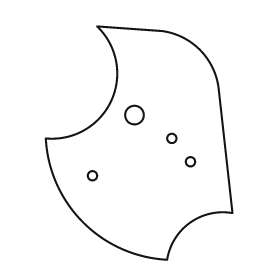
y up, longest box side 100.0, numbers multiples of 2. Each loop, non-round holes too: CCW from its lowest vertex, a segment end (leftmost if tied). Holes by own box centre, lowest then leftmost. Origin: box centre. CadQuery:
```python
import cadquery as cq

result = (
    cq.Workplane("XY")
    .moveTo(12.0, -50.0)
    .threePointArc((22.0, -34.0), (40.0, -30.0))
    .lineTo(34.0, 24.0)
    .threePointArc((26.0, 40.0), (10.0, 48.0))
    .lineTo(-18.0, 50.0)
    .threePointArc((-12.0, 18.0), (-40.0, 2.0))
    .threePointArc((-24.0, -34.0), (12.0, -50.0))
    .close()
    .moveTo(-20.0, -14.0)
    .circle(2.0)
    .moveTo(22.0, -8.0)
    .circle(2.0)
    .moveTo(14.0, 2.0)
    .circle(2.0)
    .moveTo(-2.0, 12.0)
    .circle(4.0)
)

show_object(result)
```